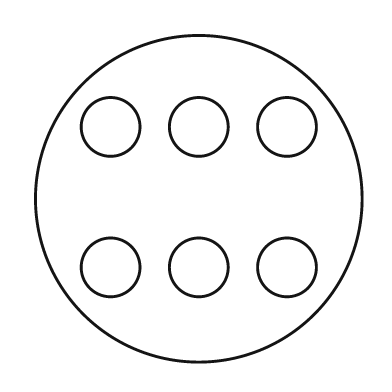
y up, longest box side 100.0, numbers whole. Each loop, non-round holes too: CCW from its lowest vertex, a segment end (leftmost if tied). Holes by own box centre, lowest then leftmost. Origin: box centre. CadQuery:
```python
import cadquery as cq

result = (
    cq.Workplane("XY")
    .moveTo(0.0, 0.0)
    .circle(50.0)
    .moveTo(-27.0, -21.0)
    .circle(9.0)
    .moveTo(0.0, -21.0)
    .circle(9.0)
    .moveTo(27.0, -21.0)
    .circle(9.0)
    .moveTo(-27.0, 22.0)
    .circle(9.0)
    .moveTo(0.0, 22.0)
    .circle(9.0)
    .moveTo(27.0, 22.0)
    .circle(9.0)
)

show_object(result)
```